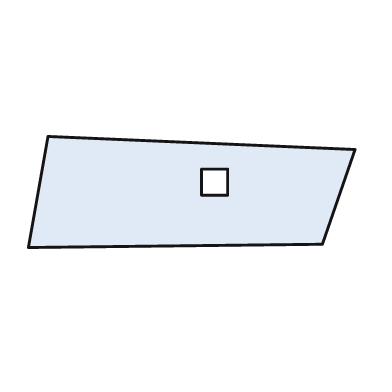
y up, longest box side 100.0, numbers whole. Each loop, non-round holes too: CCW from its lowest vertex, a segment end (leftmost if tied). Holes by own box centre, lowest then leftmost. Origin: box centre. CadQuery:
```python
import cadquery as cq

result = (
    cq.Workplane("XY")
    .moveTo(-50.0, -17.0)
    .lineTo(40.0, -16.0)
    .lineTo(50.0, 13.0)
    .lineTo(-44.0, 17.0)
    .close()
    .moveTo(3.0, -1.0)
    .lineTo(11.0, -1.0)
    .lineTo(11.0, 7.0)
    .lineTo(3.0, 7.0)
    .close()
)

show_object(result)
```